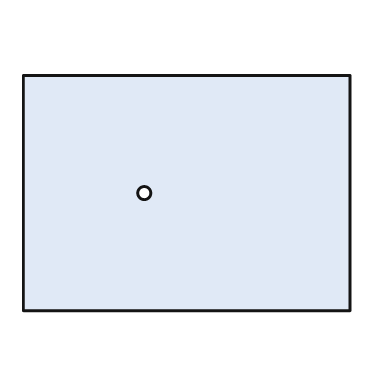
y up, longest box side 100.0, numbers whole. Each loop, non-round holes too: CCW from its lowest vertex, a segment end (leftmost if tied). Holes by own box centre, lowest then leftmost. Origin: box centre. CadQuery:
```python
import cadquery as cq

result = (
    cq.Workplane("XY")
    .moveTo(-50.0, -36.0)
    .lineTo(50.0, -36.0)
    .lineTo(50.0, 36.0)
    .lineTo(-50.0, 36.0)
    .close()
    .moveTo(-13.0, 0.0)
    .circle(2.0)
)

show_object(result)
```